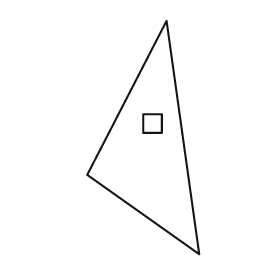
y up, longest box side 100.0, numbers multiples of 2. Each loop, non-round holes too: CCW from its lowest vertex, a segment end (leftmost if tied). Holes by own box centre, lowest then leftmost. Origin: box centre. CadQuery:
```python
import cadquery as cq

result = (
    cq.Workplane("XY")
    .moveTo(24.0, -50.0)
    .lineTo(10.0, 50.0)
    .lineTo(-24.0, -16.0)
    .close()
    .moveTo(0.0, 2.0)
    .lineTo(8.0, 2.0)
    .lineTo(8.0, 10.0)
    .lineTo(0.0, 10.0)
    .close()
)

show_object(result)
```